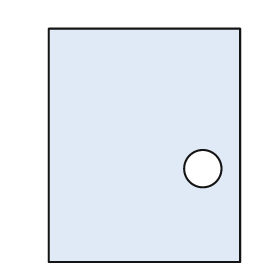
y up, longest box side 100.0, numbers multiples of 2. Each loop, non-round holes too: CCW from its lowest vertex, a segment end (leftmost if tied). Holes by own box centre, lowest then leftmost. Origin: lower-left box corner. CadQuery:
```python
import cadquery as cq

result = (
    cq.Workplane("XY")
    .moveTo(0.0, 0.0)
    .lineTo(82.0, 0.0)
    .lineTo(82.0, 100.0)
    .lineTo(0.0, 100.0)
    .close()
    .moveTo(66.0, 40.0)
    .circle(8.0)
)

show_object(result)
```